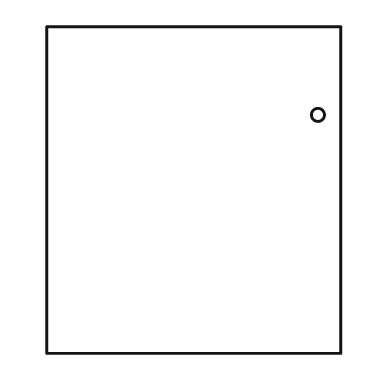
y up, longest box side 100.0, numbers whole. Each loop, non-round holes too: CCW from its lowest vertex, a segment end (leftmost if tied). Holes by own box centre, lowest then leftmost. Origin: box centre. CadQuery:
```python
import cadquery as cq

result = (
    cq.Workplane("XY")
    .moveTo(-45.0, -50.0)
    .lineTo(45.0, -50.0)
    .lineTo(45.0, 50.0)
    .lineTo(-45.0, 50.0)
    .close()
    .moveTo(38.0, 23.0)
    .circle(2.0)
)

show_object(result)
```